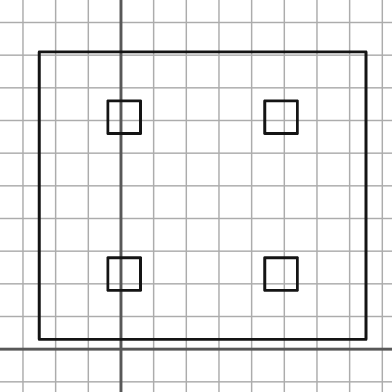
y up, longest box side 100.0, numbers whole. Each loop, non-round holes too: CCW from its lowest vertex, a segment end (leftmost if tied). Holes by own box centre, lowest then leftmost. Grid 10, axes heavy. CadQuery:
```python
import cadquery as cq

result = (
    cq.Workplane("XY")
    .moveTo(-25.0, 3.0)
    .lineTo(75.0, 3.0)
    .lineTo(75.0, 91.0)
    .lineTo(-25.0, 91.0)
    .close()
    .moveTo(-4.0, 18.0)
    .lineTo(6.0, 18.0)
    .lineTo(6.0, 28.0)
    .lineTo(-4.0, 28.0)
    .close()
    .moveTo(44.0, 18.0)
    .lineTo(54.0, 18.0)
    .lineTo(54.0, 28.0)
    .lineTo(44.0, 28.0)
    .close()
    .moveTo(-4.0, 66.0)
    .lineTo(6.0, 66.0)
    .lineTo(6.0, 76.0)
    .lineTo(-4.0, 76.0)
    .close()
    .moveTo(44.0, 66.0)
    .lineTo(54.0, 66.0)
    .lineTo(54.0, 76.0)
    .lineTo(44.0, 76.0)
    .close()
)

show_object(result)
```